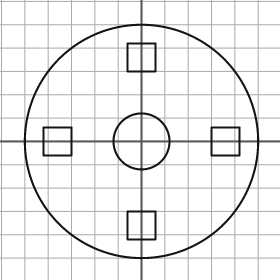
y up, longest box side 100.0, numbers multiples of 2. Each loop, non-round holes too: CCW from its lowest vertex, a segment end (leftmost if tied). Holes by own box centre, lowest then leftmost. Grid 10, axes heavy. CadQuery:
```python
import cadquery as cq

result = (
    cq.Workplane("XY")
    .moveTo(0.0, 0.0)
    .circle(50.0)
    .moveTo(-6.0, -42.0)
    .lineTo(6.0, -42.0)
    .lineTo(6.0, -30.0)
    .lineTo(-6.0, -30.0)
    .close()
    .moveTo(-42.0, -6.0)
    .lineTo(-30.0, -6.0)
    .lineTo(-30.0, 6.0)
    .lineTo(-42.0, 6.0)
    .close()
    .moveTo(0.0, 0.0)
    .circle(12.0)
    .moveTo(30.0, -6.0)
    .lineTo(42.0, -6.0)
    .lineTo(42.0, 6.0)
    .lineTo(30.0, 6.0)
    .close()
    .moveTo(-6.0, 30.0)
    .lineTo(6.0, 30.0)
    .lineTo(6.0, 42.0)
    .lineTo(-6.0, 42.0)
    .close()
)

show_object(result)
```